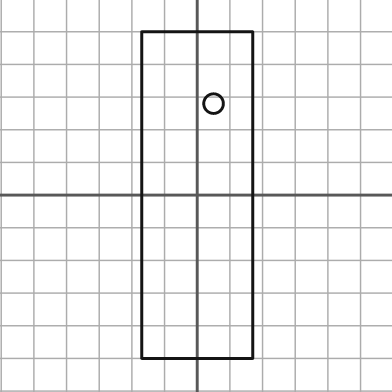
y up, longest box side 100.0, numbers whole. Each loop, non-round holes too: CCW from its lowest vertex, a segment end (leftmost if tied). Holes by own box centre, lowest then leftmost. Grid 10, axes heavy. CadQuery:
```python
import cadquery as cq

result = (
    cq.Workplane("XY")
    .moveTo(-17.0, -50.0)
    .lineTo(17.0, -50.0)
    .lineTo(17.0, 50.0)
    .lineTo(-17.0, 50.0)
    .close()
    .moveTo(5.0, 28.0)
    .circle(3.0)
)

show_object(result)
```